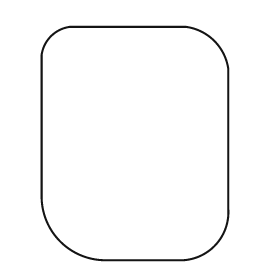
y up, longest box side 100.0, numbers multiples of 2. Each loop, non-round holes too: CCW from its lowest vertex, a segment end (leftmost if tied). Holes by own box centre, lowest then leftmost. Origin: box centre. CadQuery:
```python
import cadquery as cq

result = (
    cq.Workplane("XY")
    .moveTo(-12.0, -50.0)
    .lineTo(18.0, -50.0)
    .threePointArc((34.0, -44.0), (40.0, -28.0))
    .lineTo(40.0, 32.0)
    .threePointArc((34.0, 44.0), (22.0, 50.0))
    .lineTo(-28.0, 50.0)
    .threePointArc((-36.0, 46.0), (-40.0, 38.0))
    .lineTo(-40.0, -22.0)
    .threePointArc((-32.0, -42.0), (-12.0, -50.0))
    .close()
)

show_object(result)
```